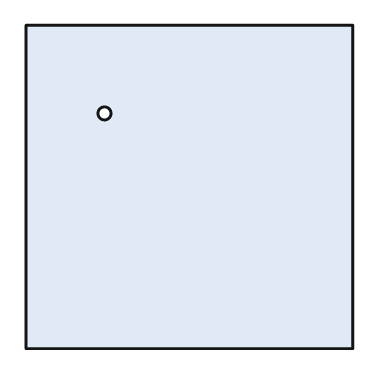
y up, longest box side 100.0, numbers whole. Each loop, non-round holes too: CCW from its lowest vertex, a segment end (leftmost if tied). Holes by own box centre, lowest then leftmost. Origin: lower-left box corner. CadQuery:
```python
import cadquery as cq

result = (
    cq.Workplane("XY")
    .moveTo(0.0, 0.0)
    .lineTo(100.0, 0.0)
    .lineTo(100.0, 99.0)
    .lineTo(0.0, 99.0)
    .close()
    .moveTo(24.0, 72.0)
    .circle(2.0)
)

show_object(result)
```